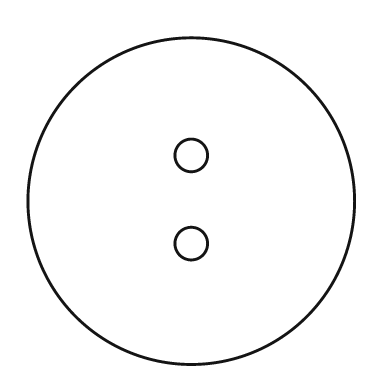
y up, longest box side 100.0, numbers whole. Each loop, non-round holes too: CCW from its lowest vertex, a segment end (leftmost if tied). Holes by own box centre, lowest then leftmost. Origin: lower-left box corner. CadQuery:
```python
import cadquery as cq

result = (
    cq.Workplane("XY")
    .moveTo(50.0, 50.0)
    .circle(50.0)
    .moveTo(50.0, 37.0)
    .circle(5.0)
    .moveTo(50.0, 64.0)
    .circle(5.0)
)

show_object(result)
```